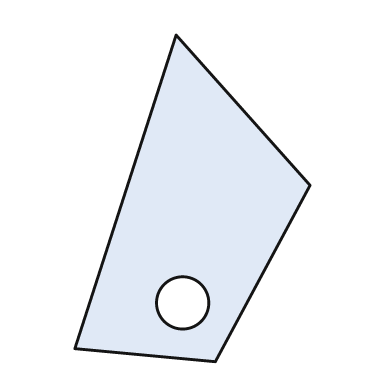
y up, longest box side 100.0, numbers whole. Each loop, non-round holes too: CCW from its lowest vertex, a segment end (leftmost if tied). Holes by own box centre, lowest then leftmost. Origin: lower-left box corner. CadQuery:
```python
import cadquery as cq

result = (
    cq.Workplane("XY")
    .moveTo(43.0, 0.0)
    .lineTo(72.0, 54.0)
    .lineTo(31.0, 100.0)
    .lineTo(0.0, 4.0)
    .close()
    .moveTo(33.0, 18.0)
    .circle(8.0)
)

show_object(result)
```